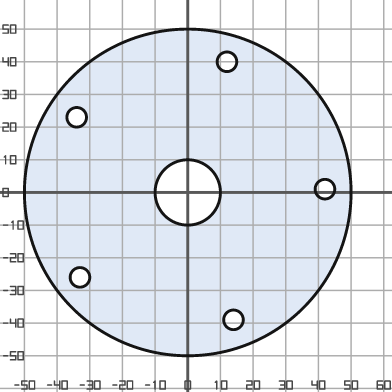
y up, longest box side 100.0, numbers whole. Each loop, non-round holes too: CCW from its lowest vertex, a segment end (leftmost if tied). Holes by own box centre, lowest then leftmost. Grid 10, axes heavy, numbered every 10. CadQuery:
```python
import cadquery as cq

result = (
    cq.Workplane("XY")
    .moveTo(0.0, 0.0)
    .circle(50.0)
    .moveTo(14.0, -39.0)
    .circle(3.0)
    .moveTo(-33.0, -26.0)
    .circle(3.0)
    .moveTo(0.0, 0.0)
    .circle(10.0)
    .moveTo(42.0, 1.0)
    .circle(3.0)
    .moveTo(-34.0, 23.0)
    .circle(3.0)
    .moveTo(12.0, 40.0)
    .circle(3.0)
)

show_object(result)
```